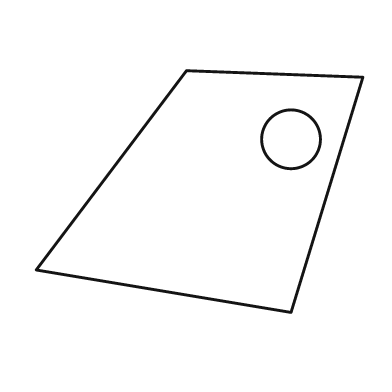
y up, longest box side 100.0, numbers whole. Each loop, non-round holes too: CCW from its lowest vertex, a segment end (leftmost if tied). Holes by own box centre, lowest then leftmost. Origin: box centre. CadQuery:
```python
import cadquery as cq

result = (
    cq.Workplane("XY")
    .moveTo(28.0, -37.0)
    .lineTo(50.0, 35.0)
    .lineTo(-4.0, 37.0)
    .lineTo(-50.0, -24.0)
    .close()
    .moveTo(28.0, 16.0)
    .circle(9.0)
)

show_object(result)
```